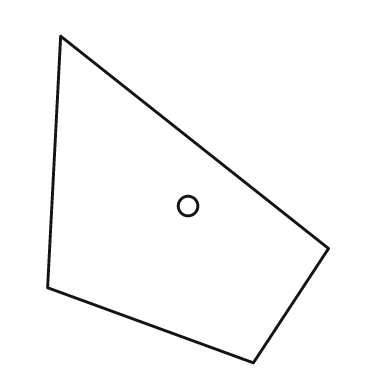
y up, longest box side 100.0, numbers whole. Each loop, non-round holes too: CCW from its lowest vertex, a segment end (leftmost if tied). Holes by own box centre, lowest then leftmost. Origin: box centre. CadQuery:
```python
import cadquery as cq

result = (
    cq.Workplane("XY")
    .moveTo(20.0, -50.0)
    .lineTo(43.0, -15.0)
    .lineTo(-39.0, 50.0)
    .lineTo(-43.0, -27.0)
    .close()
    .moveTo(0.0, -2.0)
    .circle(3.0)
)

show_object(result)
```